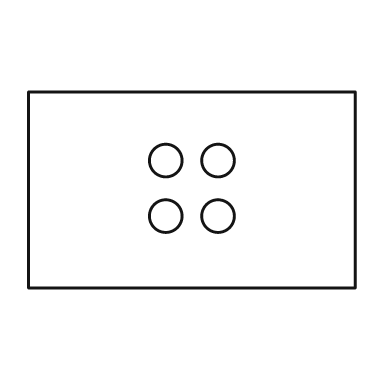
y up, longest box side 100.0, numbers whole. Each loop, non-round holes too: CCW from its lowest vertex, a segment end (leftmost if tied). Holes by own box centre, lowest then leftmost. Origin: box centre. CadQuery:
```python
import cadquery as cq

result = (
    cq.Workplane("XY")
    .moveTo(-50.0, -30.0)
    .lineTo(50.0, -30.0)
    .lineTo(50.0, 30.0)
    .lineTo(-50.0, 30.0)
    .close()
    .moveTo(-8.0, -8.0)
    .circle(5.0)
    .moveTo(8.0, -8.0)
    .circle(5.0)
    .moveTo(-8.0, 9.0)
    .circle(5.0)
    .moveTo(8.0, 9.0)
    .circle(5.0)
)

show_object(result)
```